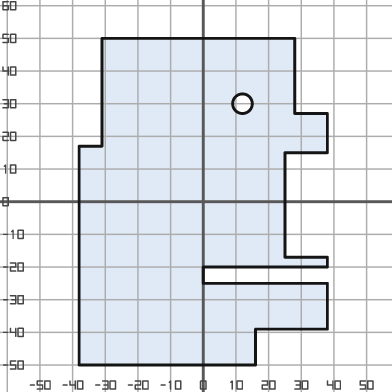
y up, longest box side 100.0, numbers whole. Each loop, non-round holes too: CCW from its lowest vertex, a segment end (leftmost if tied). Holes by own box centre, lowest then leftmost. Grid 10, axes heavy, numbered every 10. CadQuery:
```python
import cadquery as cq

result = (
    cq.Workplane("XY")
    .moveTo(-38.0, -50.0)
    .lineTo(16.0, -50.0)
    .lineTo(16.0, -39.0)
    .lineTo(38.0, -39.0)
    .lineTo(38.0, -25.0)
    .lineTo(0.0, -25.0)
    .lineTo(0.0, -20.0)
    .lineTo(38.0, -20.0)
    .lineTo(38.0, -17.0)
    .lineTo(25.0, -17.0)
    .lineTo(25.0, 15.0)
    .lineTo(38.0, 15.0)
    .lineTo(38.0, 27.0)
    .lineTo(28.0, 27.0)
    .lineTo(28.0, 50.0)
    .lineTo(-31.0, 50.0)
    .lineTo(-31.0, 17.0)
    .lineTo(-38.0, 17.0)
    .close()
    .moveTo(12.0, 30.0)
    .circle(3.0)
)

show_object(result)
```